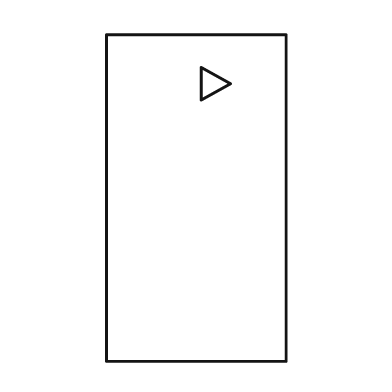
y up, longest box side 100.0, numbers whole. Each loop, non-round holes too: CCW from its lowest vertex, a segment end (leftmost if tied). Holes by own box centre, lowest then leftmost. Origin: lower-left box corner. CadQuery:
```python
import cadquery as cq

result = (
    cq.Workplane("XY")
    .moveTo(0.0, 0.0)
    .lineTo(55.0, 0.0)
    .lineTo(55.0, 100.0)
    .lineTo(0.0, 100.0)
    .close()
    .moveTo(29.0, 80.0)
    .lineTo(38.0, 85.0)
    .lineTo(29.0, 90.0)
    .close()
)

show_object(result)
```